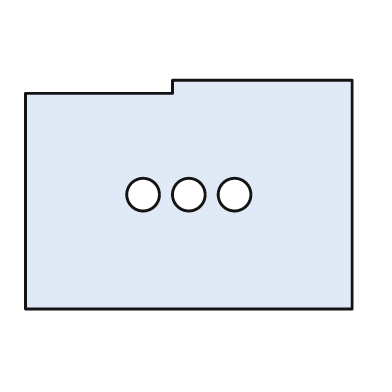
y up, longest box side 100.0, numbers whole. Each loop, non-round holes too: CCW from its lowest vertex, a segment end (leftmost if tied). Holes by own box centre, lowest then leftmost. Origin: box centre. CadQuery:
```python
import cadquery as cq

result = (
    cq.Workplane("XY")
    .moveTo(-50.0, -35.0)
    .lineTo(50.0, -35.0)
    .lineTo(50.0, 35.0)
    .lineTo(-5.0, 35.0)
    .lineTo(-5.0, 31.0)
    .lineTo(-50.0, 31.0)
    .close()
    .moveTo(-14.0, 0.0)
    .circle(5.0)
    .moveTo(0.0, 0.0)
    .circle(5.0)
    .moveTo(14.0, 0.0)
    .circle(5.0)
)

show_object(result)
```